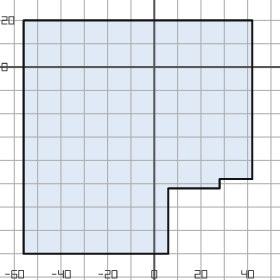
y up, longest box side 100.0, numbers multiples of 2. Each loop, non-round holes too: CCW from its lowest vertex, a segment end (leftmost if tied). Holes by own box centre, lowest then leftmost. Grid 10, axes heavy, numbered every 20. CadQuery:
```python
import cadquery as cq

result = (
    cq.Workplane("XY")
    .moveTo(-56.0, -80.0)
    .lineTo(6.0, -80.0)
    .lineTo(6.0, -52.0)
    .lineTo(28.0, -52.0)
    .lineTo(28.0, -48.0)
    .lineTo(42.0, -48.0)
    .lineTo(42.0, 20.0)
    .lineTo(-56.0, 20.0)
    .close()
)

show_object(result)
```